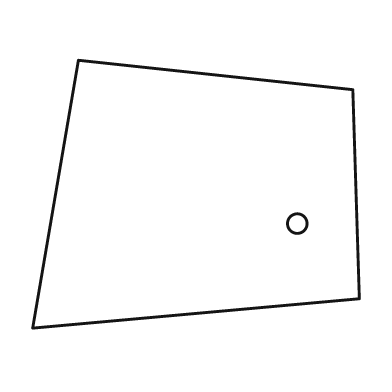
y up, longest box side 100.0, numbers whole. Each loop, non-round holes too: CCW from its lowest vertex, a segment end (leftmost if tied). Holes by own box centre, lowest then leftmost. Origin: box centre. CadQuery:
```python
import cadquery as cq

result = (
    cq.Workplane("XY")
    .moveTo(-50.0, -41.0)
    .lineTo(50.0, -32.0)
    .lineTo(48.0, 32.0)
    .lineTo(-36.0, 41.0)
    .close()
    .moveTo(31.0, -9.0)
    .circle(3.0)
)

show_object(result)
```